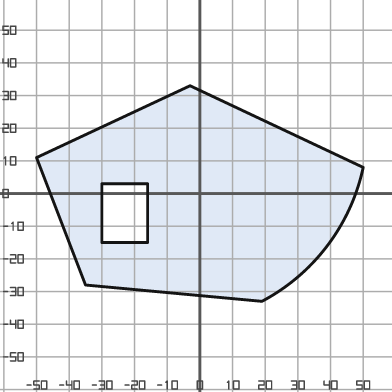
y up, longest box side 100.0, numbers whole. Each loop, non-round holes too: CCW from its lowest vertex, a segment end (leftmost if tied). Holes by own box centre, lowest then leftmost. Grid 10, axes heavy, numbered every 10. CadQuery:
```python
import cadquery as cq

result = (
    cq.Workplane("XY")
    .moveTo(19.0, -33.0)
    .threePointArc((39.0, -16.0), (50.0, 8.0))
    .lineTo(-3.0, 33.0)
    .lineTo(-50.0, 11.0)
    .lineTo(-35.0, -28.0)
    .close()
    .moveTo(-30.0, -15.0)
    .lineTo(-16.0, -15.0)
    .lineTo(-16.0, 3.0)
    .lineTo(-30.0, 3.0)
    .close()
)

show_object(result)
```